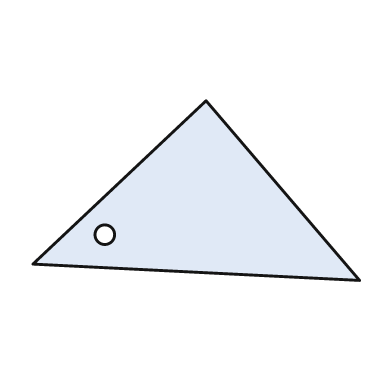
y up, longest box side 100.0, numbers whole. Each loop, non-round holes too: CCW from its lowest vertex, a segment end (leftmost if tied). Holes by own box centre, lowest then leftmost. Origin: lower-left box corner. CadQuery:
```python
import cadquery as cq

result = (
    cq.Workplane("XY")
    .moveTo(100.0, 0.0)
    .lineTo(53.0, 55.0)
    .lineTo(0.0, 5.0)
    .close()
    .moveTo(22.0, 14.0)
    .circle(3.0)
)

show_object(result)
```